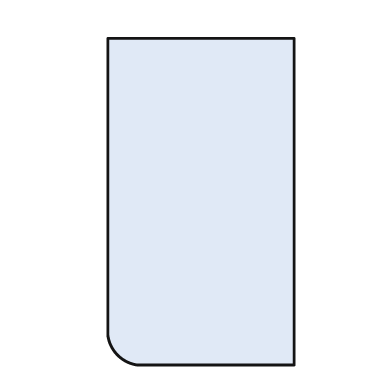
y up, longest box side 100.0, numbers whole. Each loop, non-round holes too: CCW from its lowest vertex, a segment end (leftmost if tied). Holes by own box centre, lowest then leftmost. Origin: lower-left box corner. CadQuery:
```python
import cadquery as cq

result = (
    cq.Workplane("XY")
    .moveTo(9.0, 0.0)
    .lineTo(57.0, 0.0)
    .lineTo(57.0, 100.0)
    .lineTo(0.0, 100.0)
    .lineTo(0.0, 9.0)
    .threePointArc((3.0, 3.0), (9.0, 0.0))
    .close()
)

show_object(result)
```